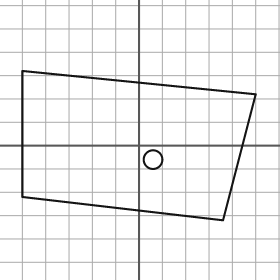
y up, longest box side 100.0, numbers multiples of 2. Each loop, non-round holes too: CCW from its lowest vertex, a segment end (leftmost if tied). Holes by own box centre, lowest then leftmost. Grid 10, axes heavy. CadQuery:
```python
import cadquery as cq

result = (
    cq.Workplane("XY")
    .moveTo(36.0, -32.0)
    .lineTo(50.0, 22.0)
    .lineTo(-50.0, 32.0)
    .lineTo(-50.0, -22.0)
    .close()
    .moveTo(6.0, -6.0)
    .circle(4.0)
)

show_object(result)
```